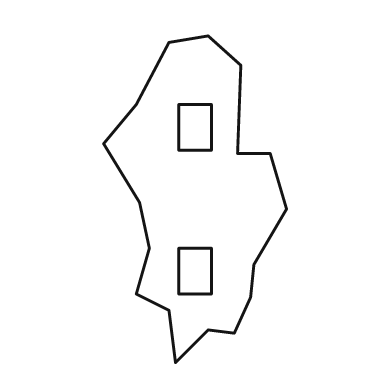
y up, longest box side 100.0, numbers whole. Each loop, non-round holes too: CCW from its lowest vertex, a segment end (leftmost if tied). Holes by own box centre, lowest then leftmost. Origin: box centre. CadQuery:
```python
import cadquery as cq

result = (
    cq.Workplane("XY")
    .moveTo(-6.0, -50.0)
    .lineTo(4.0, -40.0)
    .lineTo(12.0, -41.0)
    .lineTo(17.0, -30.0)
    .lineTo(18.0, -20.0)
    .lineTo(28.0, -3.0)
    .lineTo(23.0, 14.0)
    .lineTo(13.0, 14.0)
    .lineTo(14.0, 41.0)
    .lineTo(4.0, 50.0)
    .lineTo(-8.0, 48.0)
    .lineTo(-18.0, 29.0)
    .lineTo(-28.0, 17.0)
    .lineTo(-17.0, -1.0)
    .lineTo(-14.0, -15.0)
    .lineTo(-18.0, -29.0)
    .lineTo(-8.0, -34.0)
    .close()
    .moveTo(-5.0, -29.0)
    .lineTo(5.0, -29.0)
    .lineTo(5.0, -15.0)
    .lineTo(-5.0, -15.0)
    .close()
    .moveTo(-5.0, 15.0)
    .lineTo(5.0, 15.0)
    .lineTo(5.0, 29.0)
    .lineTo(-5.0, 29.0)
    .close()
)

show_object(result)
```